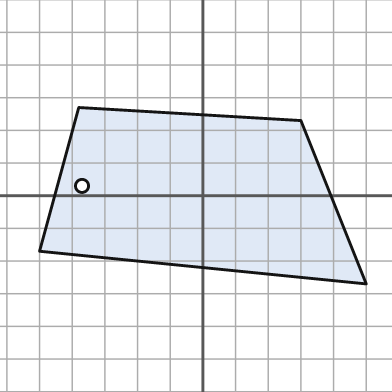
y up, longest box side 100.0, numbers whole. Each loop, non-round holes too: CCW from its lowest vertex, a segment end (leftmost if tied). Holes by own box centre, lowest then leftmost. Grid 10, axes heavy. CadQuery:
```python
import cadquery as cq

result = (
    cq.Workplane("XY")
    .moveTo(50.0, -27.0)
    .lineTo(30.0, 23.0)
    .lineTo(-38.0, 27.0)
    .lineTo(-50.0, -17.0)
    .close()
    .moveTo(-37.0, 3.0)
    .circle(2.0)
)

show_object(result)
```